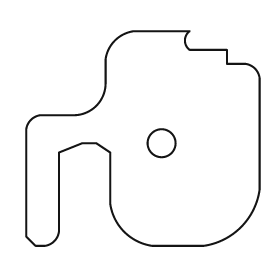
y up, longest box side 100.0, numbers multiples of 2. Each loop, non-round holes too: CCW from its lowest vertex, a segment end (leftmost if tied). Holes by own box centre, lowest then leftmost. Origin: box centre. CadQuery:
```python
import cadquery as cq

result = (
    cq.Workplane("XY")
    .moveTo(-46.0, -46.0)
    .lineTo(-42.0, -46.0)
    .threePointArc((-38.0, -44.0), (-36.0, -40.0))
    .lineTo(-36.0, -6.0)
    .lineTo(-26.0, -2.0)
    .lineTo(-20.0, -2.0)
    .lineTo(-14.0, -6.0)
    .lineTo(-14.0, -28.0)
    .threePointArc((-8.0, -40.0), (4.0, -46.0))
    .lineTo(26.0, -46.0)
    .threePointArc((42.0, -38.0), (50.0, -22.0))
    .lineTo(50.0, 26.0)
    .threePointArc((48.0, 30.0), (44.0, 32.0))
    .lineTo(36.0, 32.0)
    .lineTo(36.0, 38.0)
    .lineTo(20.0, 38.0)
    .threePointArc((18.0, 42.0), (20.0, 46.0))
    .lineTo(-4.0, 46.0)
    .threePointArc((-12.0, 42.0), (-16.0, 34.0))
    .lineTo(-16.0, 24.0)
    .threePointArc((-20.0, 14.0), (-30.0, 10.0))
    .lineTo(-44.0, 10.0)
    .threePointArc((-48.0, 8.0), (-50.0, 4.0))
    .lineTo(-50.0, -42.0)
    .close()
    .moveTo(8.0, -2.0)
    .circle(6.0)
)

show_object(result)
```